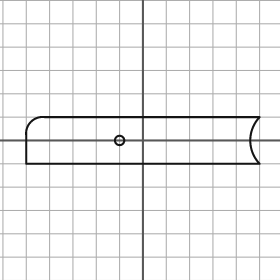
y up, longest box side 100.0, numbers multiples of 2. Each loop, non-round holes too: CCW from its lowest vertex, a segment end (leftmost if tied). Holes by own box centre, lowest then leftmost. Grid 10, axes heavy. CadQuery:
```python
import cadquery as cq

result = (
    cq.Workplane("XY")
    .moveTo(-50.0, -10.0)
    .lineTo(50.0, -10.0)
    .threePointArc((46.0, 0.0), (50.0, 10.0))
    .lineTo(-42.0, 10.0)
    .threePointArc((-48.0, 8.0), (-50.0, 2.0))
    .close()
    .moveTo(-10.0, 0.0)
    .circle(2.0)
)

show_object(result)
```